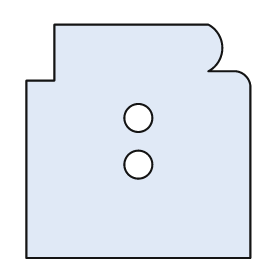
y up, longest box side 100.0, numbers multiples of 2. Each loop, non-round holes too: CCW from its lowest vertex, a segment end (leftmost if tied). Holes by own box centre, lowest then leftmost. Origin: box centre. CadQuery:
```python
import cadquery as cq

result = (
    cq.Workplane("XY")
    .moveTo(-48.0, -50.0)
    .lineTo(48.0, -50.0)
    .lineTo(48.0, 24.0)
    .threePointArc((46.0, 28.0), (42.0, 30.0))
    .lineTo(30.0, 30.0)
    .threePointArc((36.0, 40.0), (30.0, 50.0))
    .lineTo(-36.0, 50.0)
    .lineTo(-36.0, 26.0)
    .lineTo(-48.0, 26.0)
    .close()
    .moveTo(0.0, -10.0)
    .circle(6.0)
    .moveTo(0.0, 10.0)
    .circle(6.0)
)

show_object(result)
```